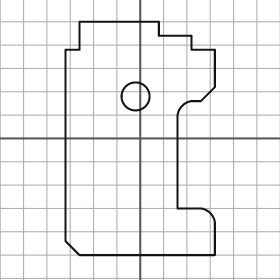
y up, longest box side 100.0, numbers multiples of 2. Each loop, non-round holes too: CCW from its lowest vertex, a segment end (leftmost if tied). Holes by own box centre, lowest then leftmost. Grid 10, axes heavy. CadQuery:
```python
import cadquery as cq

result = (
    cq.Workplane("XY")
    .moveTo(-26.0, -50.0)
    .lineTo(32.0, -50.0)
    .lineTo(32.0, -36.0)
    .threePointArc((30.0, -32.0), (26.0, -30.0))
    .lineTo(16.0, -30.0)
    .lineTo(16.0, 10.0)
    .threePointArc((18.0, 14.0), (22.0, 16.0))
    .lineTo(26.0, 16.0)
    .lineTo(32.0, 22.0)
    .lineTo(32.0, 38.0)
    .lineTo(22.0, 38.0)
    .lineTo(22.0, 44.0)
    .lineTo(8.0, 44.0)
    .lineTo(8.0, 50.0)
    .lineTo(-26.0, 50.0)
    .lineTo(-26.0, 38.0)
    .lineTo(-32.0, 38.0)
    .lineTo(-32.0, -44.0)
    .close()
    .moveTo(-2.0, 18.0)
    .circle(6.0)
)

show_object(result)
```